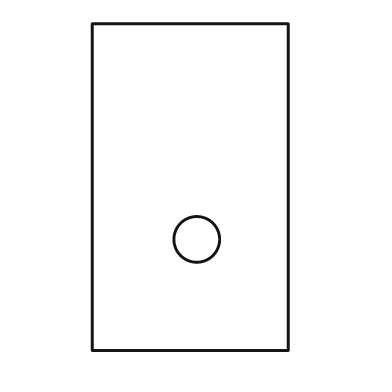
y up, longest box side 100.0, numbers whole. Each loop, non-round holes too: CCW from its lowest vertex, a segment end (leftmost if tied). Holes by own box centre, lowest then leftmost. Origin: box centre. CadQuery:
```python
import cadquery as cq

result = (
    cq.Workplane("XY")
    .moveTo(-30.0, -50.0)
    .lineTo(30.0, -50.0)
    .lineTo(30.0, 50.0)
    .lineTo(-30.0, 50.0)
    .close()
    .moveTo(2.0, -16.0)
    .circle(7.0)
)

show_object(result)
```